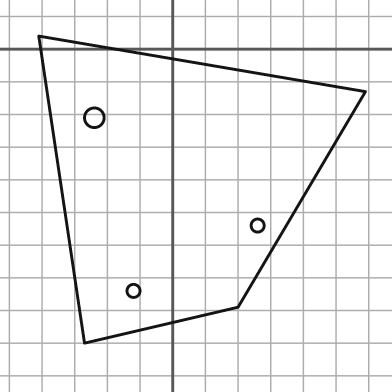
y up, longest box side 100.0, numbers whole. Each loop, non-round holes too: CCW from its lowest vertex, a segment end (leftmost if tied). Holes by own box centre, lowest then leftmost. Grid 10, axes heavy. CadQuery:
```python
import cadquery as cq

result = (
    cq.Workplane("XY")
    .moveTo(-27.0, -90.0)
    .lineTo(20.0, -79.0)
    .lineTo(59.0, -13.0)
    .lineTo(-41.0, 4.0)
    .close()
    .moveTo(-12.0, -74.0)
    .circle(2.0)
    .moveTo(26.0, -54.0)
    .circle(2.0)
    .moveTo(-24.0, -21.0)
    .circle(3.0)
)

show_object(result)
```